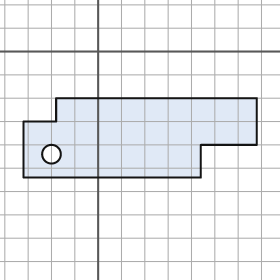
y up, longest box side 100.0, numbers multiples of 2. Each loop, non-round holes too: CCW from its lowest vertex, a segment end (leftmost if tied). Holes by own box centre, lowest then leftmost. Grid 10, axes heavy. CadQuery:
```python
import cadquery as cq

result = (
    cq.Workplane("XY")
    .moveTo(-32.0, -54.0)
    .lineTo(44.0, -54.0)
    .lineTo(44.0, -40.0)
    .lineTo(68.0, -40.0)
    .lineTo(68.0, -20.0)
    .lineTo(-18.0, -20.0)
    .lineTo(-18.0, -30.0)
    .lineTo(-32.0, -30.0)
    .close()
    .moveTo(-20.0, -44.0)
    .circle(4.0)
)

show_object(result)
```